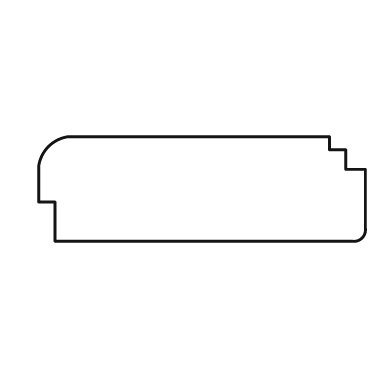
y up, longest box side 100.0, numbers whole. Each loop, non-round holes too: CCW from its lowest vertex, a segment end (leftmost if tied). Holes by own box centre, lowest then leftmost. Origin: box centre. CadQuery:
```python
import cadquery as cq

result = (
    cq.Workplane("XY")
    .moveTo(-45.0, -16.0)
    .lineTo(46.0, -16.0)
    .threePointArc((49.0, -15.0), (50.0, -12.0))
    .lineTo(50.0, 6.0)
    .lineTo(44.0, 6.0)
    .lineTo(44.0, 12.0)
    .lineTo(39.0, 12.0)
    .lineTo(39.0, 16.0)
    .lineTo(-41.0, 16.0)
    .threePointArc((-47.0, 13.0), (-50.0, 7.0))
    .lineTo(-50.0, -4.0)
    .lineTo(-45.0, -4.0)
    .close()
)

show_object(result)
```